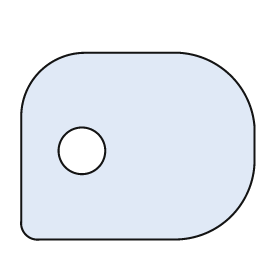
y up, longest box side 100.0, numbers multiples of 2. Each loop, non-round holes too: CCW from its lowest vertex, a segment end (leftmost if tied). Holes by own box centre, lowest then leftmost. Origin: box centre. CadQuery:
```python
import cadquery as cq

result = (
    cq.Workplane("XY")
    .moveTo(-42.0, -40.0)
    .lineTo(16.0, -40.0)
    .threePointArc((40.0, -30.0), (50.0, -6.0))
    .lineTo(50.0, 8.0)
    .threePointArc((40.0, 30.0), (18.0, 40.0))
    .lineTo(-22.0, 40.0)
    .threePointArc((-42.0, 32.0), (-50.0, 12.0))
    .lineTo(-50.0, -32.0)
    .threePointArc((-48.0, -38.0), (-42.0, -40.0))
    .close()
    .moveTo(-24.0, -2.0)
    .circle(10.0)
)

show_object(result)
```